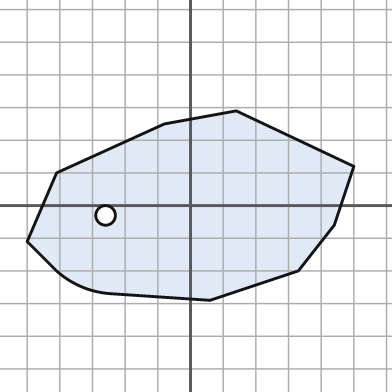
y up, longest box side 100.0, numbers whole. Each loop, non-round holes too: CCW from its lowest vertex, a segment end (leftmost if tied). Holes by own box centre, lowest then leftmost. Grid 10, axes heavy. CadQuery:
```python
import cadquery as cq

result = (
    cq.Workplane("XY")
    .moveTo(6.0, -29.0)
    .lineTo(33.0, -20.0)
    .lineTo(44.0, -6.0)
    .lineTo(50.0, 12.0)
    .lineTo(14.0, 29.0)
    .lineTo(-8.0, 25.0)
    .lineTo(-41.0, 10.0)
    .lineTo(-50.0, -11.0)
    .lineTo(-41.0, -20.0)
    .threePointArc((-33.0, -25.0), (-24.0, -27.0))
    .close()
    .moveTo(-26.0, -3.0)
    .circle(3.0)
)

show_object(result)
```